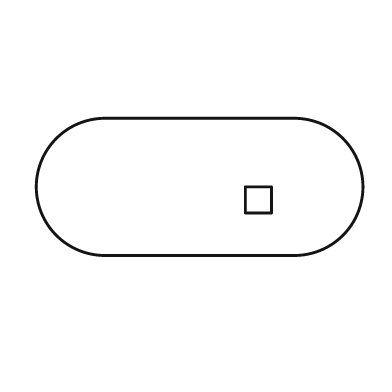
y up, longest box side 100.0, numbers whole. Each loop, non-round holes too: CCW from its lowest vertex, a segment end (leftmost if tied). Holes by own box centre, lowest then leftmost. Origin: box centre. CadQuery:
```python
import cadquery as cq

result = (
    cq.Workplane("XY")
    .moveTo(-29.0, -21.0)
    .lineTo(29.0, -21.0)
    .threePointArc((50.0, 0.0), (29.0, 21.0))
    .lineTo(-29.0, 21.0)
    .threePointArc((-50.0, 0.0), (-29.0, -21.0))
    .close()
    .moveTo(14.0, -8.0)
    .lineTo(22.0, -8.0)
    .lineTo(22.0, 0.0)
    .lineTo(14.0, 0.0)
    .close()
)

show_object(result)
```